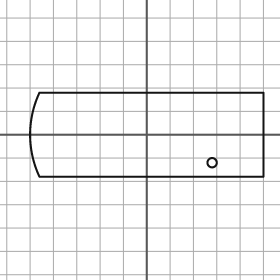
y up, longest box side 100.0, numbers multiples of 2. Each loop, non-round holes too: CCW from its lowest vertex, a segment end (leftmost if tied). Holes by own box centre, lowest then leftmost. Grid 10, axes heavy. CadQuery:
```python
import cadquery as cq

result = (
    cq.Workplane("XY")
    .moveTo(-46.0, -18.0)
    .lineTo(50.0, -18.0)
    .lineTo(50.0, 18.0)
    .lineTo(-46.0, 18.0)
    .threePointArc((-50.0, 0.0), (-46.0, -18.0))
    .close()
    .moveTo(28.0, -12.0)
    .circle(2.0)
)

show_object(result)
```